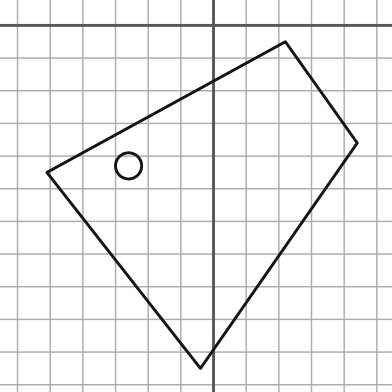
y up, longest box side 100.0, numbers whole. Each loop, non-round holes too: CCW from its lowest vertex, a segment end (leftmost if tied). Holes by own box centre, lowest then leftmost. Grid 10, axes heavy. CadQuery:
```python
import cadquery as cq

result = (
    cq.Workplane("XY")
    .moveTo(-4.0, -105.0)
    .lineTo(44.0, -36.0)
    .lineTo(22.0, -5.0)
    .lineTo(-51.0, -45.0)
    .close()
    .moveTo(-26.0, -43.0)
    .circle(4.0)
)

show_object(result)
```